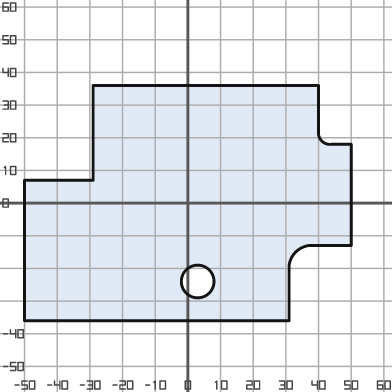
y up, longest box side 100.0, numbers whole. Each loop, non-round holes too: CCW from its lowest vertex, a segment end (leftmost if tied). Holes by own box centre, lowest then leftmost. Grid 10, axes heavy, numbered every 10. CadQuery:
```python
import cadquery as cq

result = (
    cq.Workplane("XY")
    .moveTo(-50.0, -36.0)
    .lineTo(31.0, -36.0)
    .lineTo(31.0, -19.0)
    .threePointArc((33.0, -15.0), (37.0, -13.0))
    .lineTo(50.0, -13.0)
    .lineTo(50.0, 18.0)
    .lineTo(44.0, 18.0)
    .threePointArc((41.0, 19.0), (40.0, 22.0))
    .lineTo(40.0, 36.0)
    .lineTo(-29.0, 36.0)
    .lineTo(-29.0, 7.0)
    .lineTo(-50.0, 7.0)
    .close()
    .moveTo(3.0, -24.0)
    .circle(5.0)
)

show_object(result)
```